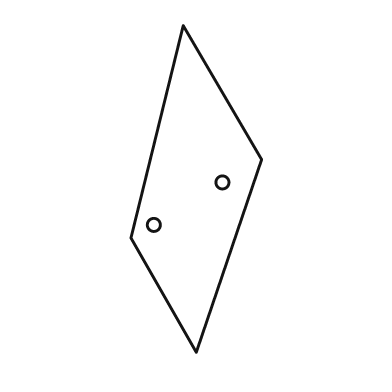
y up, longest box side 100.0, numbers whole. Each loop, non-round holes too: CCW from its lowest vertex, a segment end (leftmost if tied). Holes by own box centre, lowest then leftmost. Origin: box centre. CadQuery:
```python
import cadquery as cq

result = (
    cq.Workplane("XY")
    .moveTo(0.0, -50.0)
    .lineTo(20.0, 9.0)
    .lineTo(-4.0, 50.0)
    .lineTo(-20.0, -15.0)
    .close()
    .moveTo(-13.0, -11.0)
    .circle(2.0)
    .moveTo(8.0, 2.0)
    .circle(2.0)
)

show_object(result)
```